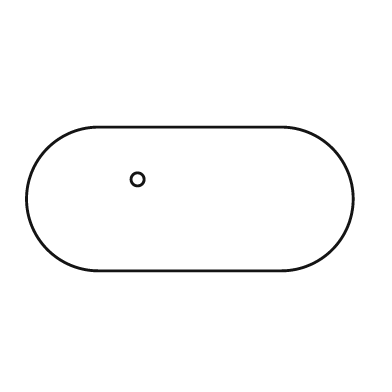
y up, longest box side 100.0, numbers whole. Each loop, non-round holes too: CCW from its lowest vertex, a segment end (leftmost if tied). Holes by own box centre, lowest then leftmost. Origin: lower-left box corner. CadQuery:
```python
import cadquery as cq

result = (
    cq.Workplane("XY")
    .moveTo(22.0, 0.0)
    .lineTo(78.0, 0.0)
    .threePointArc((100.0, 22.0), (78.0, 44.0))
    .lineTo(22.0, 44.0)
    .threePointArc((0.0, 22.0), (22.0, 0.0))
    .close()
    .moveTo(34.0, 28.0)
    .circle(2.0)
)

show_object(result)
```